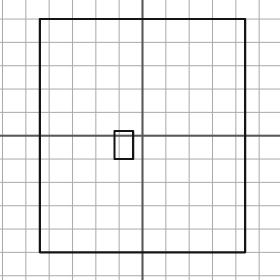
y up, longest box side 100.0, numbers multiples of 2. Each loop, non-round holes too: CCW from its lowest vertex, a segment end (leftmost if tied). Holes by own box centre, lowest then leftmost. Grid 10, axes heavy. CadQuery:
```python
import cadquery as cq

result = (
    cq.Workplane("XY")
    .moveTo(-44.0, -50.0)
    .lineTo(44.0, -50.0)
    .lineTo(44.0, 50.0)
    .lineTo(-44.0, 50.0)
    .close()
    .moveTo(-12.0, -10.0)
    .lineTo(-4.0, -10.0)
    .lineTo(-4.0, 2.0)
    .lineTo(-12.0, 2.0)
    .close()
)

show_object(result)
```